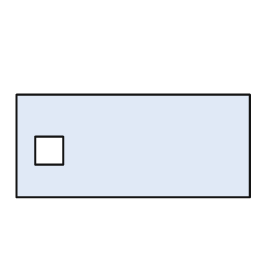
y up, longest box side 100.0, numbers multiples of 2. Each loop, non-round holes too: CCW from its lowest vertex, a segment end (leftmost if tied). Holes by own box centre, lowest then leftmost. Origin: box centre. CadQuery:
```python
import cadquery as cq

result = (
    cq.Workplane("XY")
    .moveTo(-50.0, -22.0)
    .lineTo(50.0, -22.0)
    .lineTo(50.0, 22.0)
    .lineTo(-50.0, 22.0)
    .close()
    .moveTo(-42.0, -8.0)
    .lineTo(-30.0, -8.0)
    .lineTo(-30.0, 4.0)
    .lineTo(-42.0, 4.0)
    .close()
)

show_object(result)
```